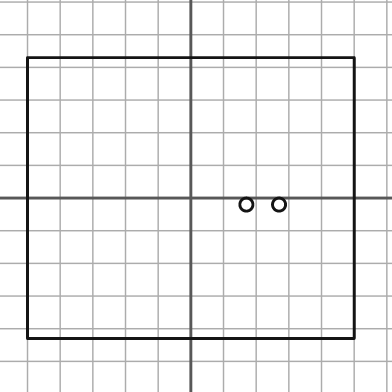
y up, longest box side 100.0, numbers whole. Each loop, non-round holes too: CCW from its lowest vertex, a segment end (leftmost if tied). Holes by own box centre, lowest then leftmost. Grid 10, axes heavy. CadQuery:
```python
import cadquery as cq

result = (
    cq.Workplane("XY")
    .moveTo(-50.0, -43.0)
    .lineTo(50.0, -43.0)
    .lineTo(50.0, 43.0)
    .lineTo(-50.0, 43.0)
    .close()
    .moveTo(17.0, -2.0)
    .circle(2.0)
    .moveTo(27.0, -2.0)
    .circle(2.0)
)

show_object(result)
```